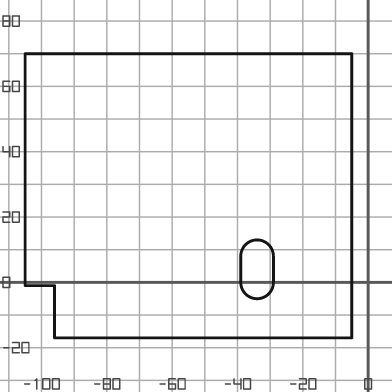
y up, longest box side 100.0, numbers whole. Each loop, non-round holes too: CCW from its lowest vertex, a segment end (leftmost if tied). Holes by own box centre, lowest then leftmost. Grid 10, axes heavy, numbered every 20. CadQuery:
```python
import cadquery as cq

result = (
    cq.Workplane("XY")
    .moveTo(-96.0, -17.0)
    .lineTo(-5.0, -17.0)
    .lineTo(-5.0, 70.0)
    .lineTo(-105.0, 70.0)
    .lineTo(-105.0, -1.0)
    .lineTo(-96.0, -1.0)
    .close()
    .moveTo(-39.0, 0.0)
    .threePointArc((-34.0, -5.0), (-29.0, 0.0))
    .lineTo(-29.0, 8.0)
    .threePointArc((-34.0, 13.0), (-39.0, 8.0))
    .close()
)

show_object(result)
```